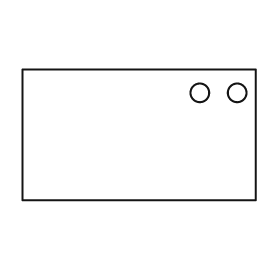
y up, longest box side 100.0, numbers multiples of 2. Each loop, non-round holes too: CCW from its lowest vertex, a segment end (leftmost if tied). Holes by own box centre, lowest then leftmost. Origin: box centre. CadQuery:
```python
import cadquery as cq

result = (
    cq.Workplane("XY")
    .moveTo(-50.0, -28.0)
    .lineTo(50.0, -28.0)
    .lineTo(50.0, 28.0)
    .lineTo(-50.0, 28.0)
    .close()
    .moveTo(26.0, 18.0)
    .circle(4.0)
    .moveTo(42.0, 18.0)
    .circle(4.0)
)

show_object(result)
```